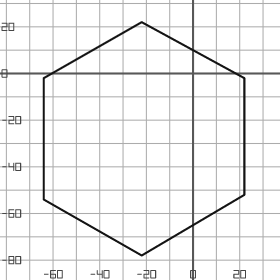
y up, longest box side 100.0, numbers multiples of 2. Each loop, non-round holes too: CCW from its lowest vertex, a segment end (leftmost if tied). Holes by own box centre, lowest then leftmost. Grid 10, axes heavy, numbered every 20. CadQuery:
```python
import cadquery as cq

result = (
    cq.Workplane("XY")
    .moveTo(-22.0, -78.0)
    .lineTo(22.0, -52.0)
    .lineTo(22.0, -2.0)
    .lineTo(-22.0, 22.0)
    .lineTo(-64.0, -2.0)
    .lineTo(-64.0, -54.0)
    .close()
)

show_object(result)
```